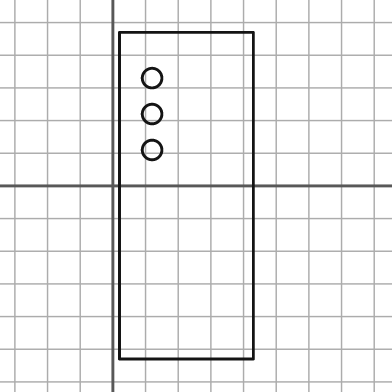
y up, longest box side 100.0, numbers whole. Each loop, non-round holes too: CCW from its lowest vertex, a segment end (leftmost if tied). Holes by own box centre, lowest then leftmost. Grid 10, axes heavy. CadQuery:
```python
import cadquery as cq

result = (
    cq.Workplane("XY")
    .moveTo(2.0, -53.0)
    .lineTo(43.0, -53.0)
    .lineTo(43.0, 47.0)
    .lineTo(2.0, 47.0)
    .close()
    .moveTo(12.0, 11.0)
    .circle(3.0)
    .moveTo(12.0, 22.0)
    .circle(3.0)
    .moveTo(12.0, 33.0)
    .circle(3.0)
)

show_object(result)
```